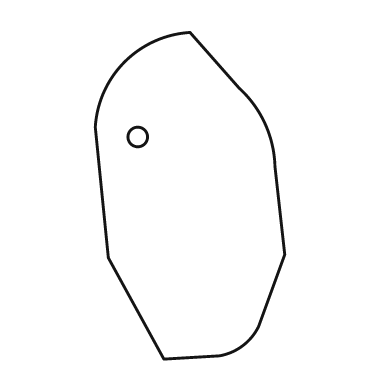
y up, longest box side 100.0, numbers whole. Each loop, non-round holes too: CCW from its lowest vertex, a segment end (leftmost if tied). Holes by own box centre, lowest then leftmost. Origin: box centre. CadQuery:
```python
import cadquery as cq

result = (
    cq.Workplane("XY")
    .moveTo(-8.0, -50.0)
    .lineTo(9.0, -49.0)
    .threePointArc((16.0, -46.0), (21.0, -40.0))
    .lineTo(29.0, -18.0)
    .lineTo(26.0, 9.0)
    .threePointArc((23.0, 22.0), (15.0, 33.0))
    .lineTo(0.0, 50.0)
    .threePointArc((-20.0, 41.0), (-29.0, 21.0))
    .lineTo(-25.0, -19.0)
    .close()
    .moveTo(-16.0, 18.0)
    .circle(3.0)
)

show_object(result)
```